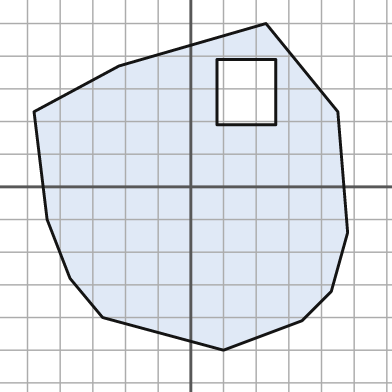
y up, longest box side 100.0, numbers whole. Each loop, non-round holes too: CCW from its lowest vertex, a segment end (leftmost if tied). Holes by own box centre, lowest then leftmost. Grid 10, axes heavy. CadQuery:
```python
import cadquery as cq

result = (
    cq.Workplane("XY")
    .moveTo(10.0, -50.0)
    .lineTo(34.0, -41.0)
    .lineTo(43.0, -32.0)
    .lineTo(48.0, -14.0)
    .lineTo(45.0, 23.0)
    .lineTo(23.0, 50.0)
    .lineTo(-22.0, 37.0)
    .lineTo(-48.0, 23.0)
    .lineTo(-44.0, -10.0)
    .lineTo(-37.0, -28.0)
    .lineTo(-27.0, -40.0)
    .close()
    .moveTo(8.0, 19.0)
    .lineTo(26.0, 19.0)
    .lineTo(26.0, 39.0)
    .lineTo(8.0, 39.0)
    .close()
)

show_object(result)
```